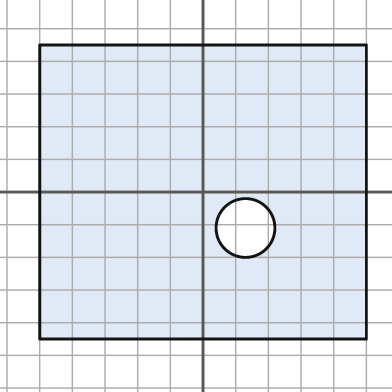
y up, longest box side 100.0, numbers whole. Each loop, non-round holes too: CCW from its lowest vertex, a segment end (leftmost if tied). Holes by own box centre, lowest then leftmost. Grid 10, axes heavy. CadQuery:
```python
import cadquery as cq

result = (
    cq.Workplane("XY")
    .moveTo(-50.0, -45.0)
    .lineTo(50.0, -45.0)
    .lineTo(50.0, 45.0)
    .lineTo(-50.0, 45.0)
    .close()
    .moveTo(13.0, -11.0)
    .circle(9.0)
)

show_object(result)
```